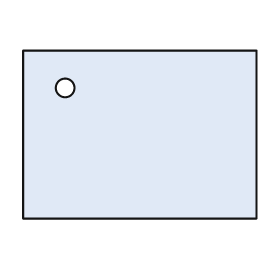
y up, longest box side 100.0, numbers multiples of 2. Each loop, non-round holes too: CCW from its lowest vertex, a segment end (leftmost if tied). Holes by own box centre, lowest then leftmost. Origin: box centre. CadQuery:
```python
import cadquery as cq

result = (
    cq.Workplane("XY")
    .moveTo(-50.0, -36.0)
    .lineTo(50.0, -36.0)
    .lineTo(50.0, 36.0)
    .lineTo(-50.0, 36.0)
    .close()
    .moveTo(-32.0, 20.0)
    .circle(4.0)
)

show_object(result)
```